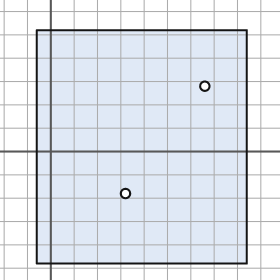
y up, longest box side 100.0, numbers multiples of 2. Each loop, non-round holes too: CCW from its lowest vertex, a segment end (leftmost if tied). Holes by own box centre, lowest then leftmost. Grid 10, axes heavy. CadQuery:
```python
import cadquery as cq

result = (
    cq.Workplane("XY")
    .moveTo(-6.0, -48.0)
    .lineTo(84.0, -48.0)
    .lineTo(84.0, 52.0)
    .lineTo(-6.0, 52.0)
    .close()
    .moveTo(32.0, -18.0)
    .circle(2.0)
    .moveTo(66.0, 28.0)
    .circle(2.0)
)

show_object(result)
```